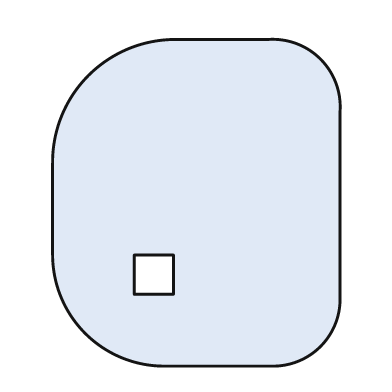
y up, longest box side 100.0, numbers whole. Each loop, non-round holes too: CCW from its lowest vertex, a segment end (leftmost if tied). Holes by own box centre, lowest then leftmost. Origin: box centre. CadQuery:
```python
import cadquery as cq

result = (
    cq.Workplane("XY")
    .moveTo(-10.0, -50.0)
    .lineTo(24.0, -50.0)
    .threePointArc((38.0, -44.0), (44.0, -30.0))
    .lineTo(44.0, 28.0)
    .threePointArc((38.0, 44.0), (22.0, 50.0))
    .lineTo(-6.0, 50.0)
    .threePointArc((-33.0, 39.0), (-44.0, 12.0))
    .lineTo(-44.0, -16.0)
    .threePointArc((-34.0, -40.0), (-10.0, -50.0))
    .close()
    .moveTo(-19.0, -28.0)
    .lineTo(-7.0, -28.0)
    .lineTo(-7.0, -16.0)
    .lineTo(-19.0, -16.0)
    .close()
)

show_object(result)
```